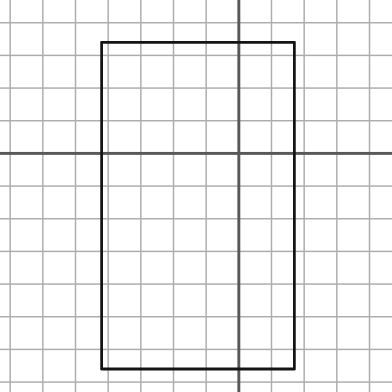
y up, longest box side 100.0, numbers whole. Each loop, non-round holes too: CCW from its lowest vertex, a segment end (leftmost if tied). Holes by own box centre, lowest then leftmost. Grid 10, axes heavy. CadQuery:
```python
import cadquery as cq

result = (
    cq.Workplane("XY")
    .moveTo(-42.0, -66.0)
    .lineTo(17.0, -66.0)
    .lineTo(17.0, 34.0)
    .lineTo(-42.0, 34.0)
    .close()
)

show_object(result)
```